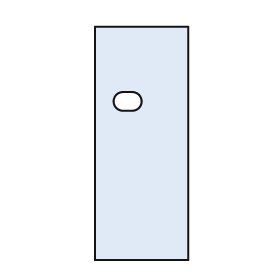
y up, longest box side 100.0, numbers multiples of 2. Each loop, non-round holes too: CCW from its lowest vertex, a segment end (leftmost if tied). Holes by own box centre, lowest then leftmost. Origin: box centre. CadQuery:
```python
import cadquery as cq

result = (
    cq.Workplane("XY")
    .moveTo(-20.0, -50.0)
    .lineTo(20.0, -50.0)
    .lineTo(20.0, 50.0)
    .lineTo(-20.0, 50.0)
    .close()
    .moveTo(-8.0, 14.0)
    .lineTo(-4.0, 14.0)
    .threePointArc((0.0, 18.0), (-4.0, 22.0))
    .lineTo(-8.0, 22.0)
    .threePointArc((-12.0, 18.0), (-8.0, 14.0))
    .close()
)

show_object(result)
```